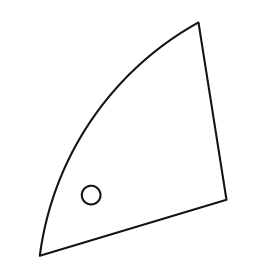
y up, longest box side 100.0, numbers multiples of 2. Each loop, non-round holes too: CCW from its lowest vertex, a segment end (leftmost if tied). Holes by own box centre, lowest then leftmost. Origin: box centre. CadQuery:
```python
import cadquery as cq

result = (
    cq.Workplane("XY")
    .moveTo(-40.0, -50.0)
    .lineTo(40.0, -26.0)
    .lineTo(28.0, 50.0)
    .threePointArc((-18.0, 8.0), (-40.0, -50.0))
    .close()
    .moveTo(-18.0, -24.0)
    .circle(4.0)
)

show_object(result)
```